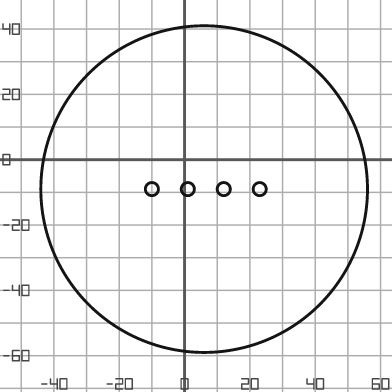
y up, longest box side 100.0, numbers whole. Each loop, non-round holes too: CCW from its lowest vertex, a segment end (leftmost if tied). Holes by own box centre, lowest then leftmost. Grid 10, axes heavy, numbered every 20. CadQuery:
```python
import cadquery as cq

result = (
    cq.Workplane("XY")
    .moveTo(6.0, -9.0)
    .circle(50.0)
    .moveTo(-10.0, -9.0)
    .circle(2.0)
    .moveTo(1.0, -9.0)
    .circle(2.0)
    .moveTo(12.0, -9.0)
    .circle(2.0)
    .moveTo(23.0, -9.0)
    .circle(2.0)
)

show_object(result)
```